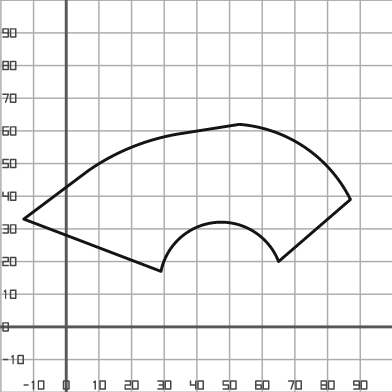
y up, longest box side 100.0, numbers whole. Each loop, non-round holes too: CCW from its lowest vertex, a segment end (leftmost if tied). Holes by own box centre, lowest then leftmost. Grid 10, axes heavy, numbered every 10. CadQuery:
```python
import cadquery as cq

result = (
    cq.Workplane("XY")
    .moveTo(29.0, 17.0)
    .threePointArc((46.0, 32.0), (65.0, 20.0))
    .lineTo(87.0, 39.0)
    .threePointArc((73.0, 55.0), (53.0, 62.0))
    .lineTo(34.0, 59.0)
    .threePointArc((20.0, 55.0), (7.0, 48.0))
    .lineTo(-13.0, 33.0)
    .close()
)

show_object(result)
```